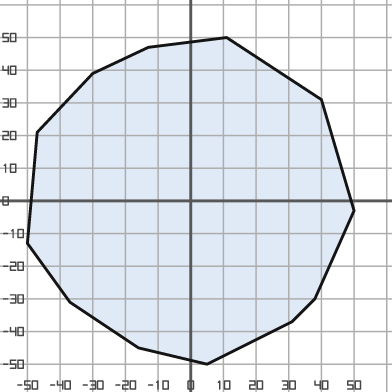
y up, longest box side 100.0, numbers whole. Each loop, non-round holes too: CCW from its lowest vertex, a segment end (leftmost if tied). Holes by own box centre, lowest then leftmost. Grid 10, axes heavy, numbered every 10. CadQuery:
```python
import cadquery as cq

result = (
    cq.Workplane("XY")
    .moveTo(5.0, -50.0)
    .lineTo(31.0, -37.0)
    .lineTo(38.0, -30.0)
    .lineTo(50.0, -3.0)
    .lineTo(40.0, 31.0)
    .lineTo(11.0, 50.0)
    .lineTo(-13.0, 47.0)
    .lineTo(-30.0, 39.0)
    .lineTo(-47.0, 21.0)
    .lineTo(-50.0, -13.0)
    .lineTo(-37.0, -31.0)
    .lineTo(-16.0, -45.0)
    .close()
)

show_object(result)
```